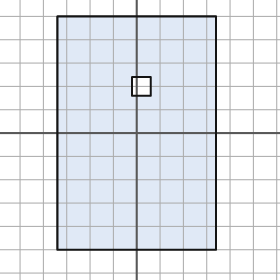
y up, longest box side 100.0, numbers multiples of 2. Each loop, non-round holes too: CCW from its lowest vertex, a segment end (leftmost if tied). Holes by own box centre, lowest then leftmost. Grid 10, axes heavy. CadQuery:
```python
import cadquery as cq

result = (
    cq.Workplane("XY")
    .moveTo(-34.0, -50.0)
    .lineTo(34.0, -50.0)
    .lineTo(34.0, 50.0)
    .lineTo(-34.0, 50.0)
    .close()
    .moveTo(-2.0, 16.0)
    .lineTo(6.0, 16.0)
    .lineTo(6.0, 24.0)
    .lineTo(-2.0, 24.0)
    .close()
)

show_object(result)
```